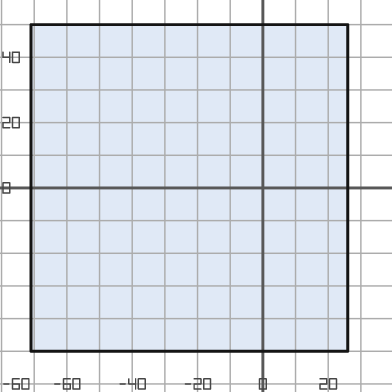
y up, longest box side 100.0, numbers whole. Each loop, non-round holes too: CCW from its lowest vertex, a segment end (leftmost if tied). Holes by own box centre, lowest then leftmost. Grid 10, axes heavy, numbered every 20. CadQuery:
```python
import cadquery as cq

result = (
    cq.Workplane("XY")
    .moveTo(-71.0, -50.0)
    .lineTo(26.0, -50.0)
    .lineTo(26.0, 50.0)
    .lineTo(-71.0, 50.0)
    .close()
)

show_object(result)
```